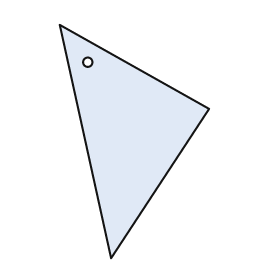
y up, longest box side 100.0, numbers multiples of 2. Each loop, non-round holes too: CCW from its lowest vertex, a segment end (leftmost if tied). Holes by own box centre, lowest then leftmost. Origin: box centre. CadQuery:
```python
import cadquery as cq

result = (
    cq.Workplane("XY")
    .moveTo(-10.0, -50.0)
    .lineTo(32.0, 14.0)
    .lineTo(-32.0, 50.0)
    .close()
    .moveTo(-20.0, 34.0)
    .circle(2.0)
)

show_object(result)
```